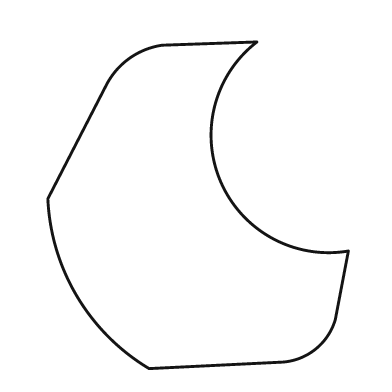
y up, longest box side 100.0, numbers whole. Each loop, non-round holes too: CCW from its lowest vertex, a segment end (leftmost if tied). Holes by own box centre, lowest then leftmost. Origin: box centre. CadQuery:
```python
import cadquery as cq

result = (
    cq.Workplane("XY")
    .moveTo(-15.0, -50.0)
    .lineTo(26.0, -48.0)
    .threePointArc((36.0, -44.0), (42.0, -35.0))
    .lineTo(46.0, -14.0)
    .threePointArc((7.0, 7.0), (18.0, 50.0))
    .lineTo(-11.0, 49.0)
    .threePointArc((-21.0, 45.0), (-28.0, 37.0))
    .lineTo(-46.0, 2.0)
    .threePointArc((-37.0, -28.0), (-15.0, -50.0))
    .close()
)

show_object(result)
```